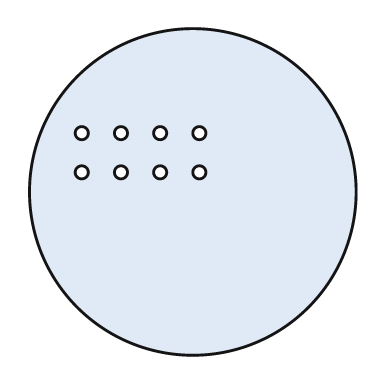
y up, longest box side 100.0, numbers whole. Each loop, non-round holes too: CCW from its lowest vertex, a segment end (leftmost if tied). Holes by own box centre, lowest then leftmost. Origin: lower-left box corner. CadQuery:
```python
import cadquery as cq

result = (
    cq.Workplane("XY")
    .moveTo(50.0, 50.0)
    .circle(50.0)
    .moveTo(16.0, 56.0)
    .circle(2.0)
    .moveTo(28.0, 56.0)
    .circle(2.0)
    .moveTo(40.0, 56.0)
    .circle(2.0)
    .moveTo(52.0, 56.0)
    .circle(2.0)
    .moveTo(16.0, 68.0)
    .circle(2.0)
    .moveTo(28.0, 68.0)
    .circle(2.0)
    .moveTo(40.0, 68.0)
    .circle(2.0)
    .moveTo(52.0, 68.0)
    .circle(2.0)
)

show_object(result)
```